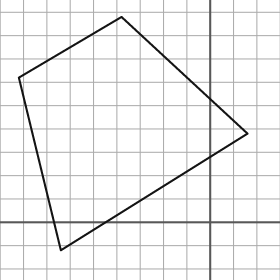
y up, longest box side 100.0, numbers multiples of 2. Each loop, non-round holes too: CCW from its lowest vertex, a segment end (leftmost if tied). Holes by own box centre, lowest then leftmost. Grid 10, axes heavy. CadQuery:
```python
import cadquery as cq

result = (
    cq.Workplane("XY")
    .moveTo(-64.0, -12.0)
    .lineTo(16.0, 38.0)
    .lineTo(-38.0, 88.0)
    .lineTo(-82.0, 62.0)
    .close()
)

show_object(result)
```